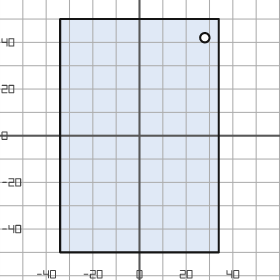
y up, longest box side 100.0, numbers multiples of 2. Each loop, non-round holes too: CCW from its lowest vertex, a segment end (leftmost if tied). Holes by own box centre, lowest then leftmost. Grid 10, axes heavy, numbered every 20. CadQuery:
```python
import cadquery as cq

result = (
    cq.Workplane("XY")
    .moveTo(-34.0, -50.0)
    .lineTo(34.0, -50.0)
    .lineTo(34.0, 50.0)
    .lineTo(-34.0, 50.0)
    .close()
    .moveTo(28.0, 42.0)
    .circle(2.0)
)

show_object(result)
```